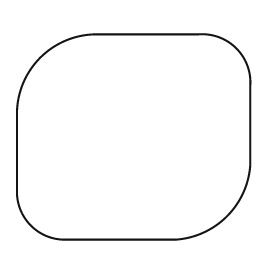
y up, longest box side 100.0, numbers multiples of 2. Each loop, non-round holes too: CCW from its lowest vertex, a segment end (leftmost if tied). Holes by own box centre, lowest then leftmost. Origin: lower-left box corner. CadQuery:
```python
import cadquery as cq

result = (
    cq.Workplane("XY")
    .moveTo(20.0, 0.0)
    .lineTo(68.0, 0.0)
    .threePointArc((90.0, 10.0), (100.0, 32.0))
    .lineTo(100.0, 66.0)
    .threePointArc((94.0, 82.0), (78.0, 88.0))
    .lineTo(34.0, 88.0)
    .threePointArc((10.0, 78.0), (0.0, 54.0))
    .lineTo(0.0, 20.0)
    .threePointArc((6.0, 6.0), (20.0, 0.0))
    .close()
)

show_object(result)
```